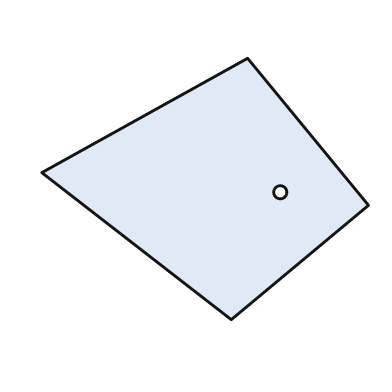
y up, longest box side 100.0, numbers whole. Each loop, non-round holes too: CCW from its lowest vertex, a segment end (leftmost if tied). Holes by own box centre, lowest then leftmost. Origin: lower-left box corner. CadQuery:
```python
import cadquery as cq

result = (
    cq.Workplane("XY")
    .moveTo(58.0, 0.0)
    .lineTo(100.0, 35.0)
    .lineTo(63.0, 80.0)
    .lineTo(0.0, 45.0)
    .close()
    .moveTo(73.0, 39.0)
    .circle(2.0)
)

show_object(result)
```